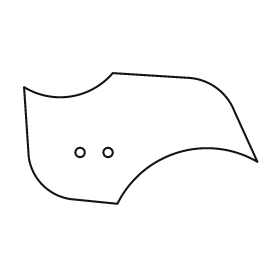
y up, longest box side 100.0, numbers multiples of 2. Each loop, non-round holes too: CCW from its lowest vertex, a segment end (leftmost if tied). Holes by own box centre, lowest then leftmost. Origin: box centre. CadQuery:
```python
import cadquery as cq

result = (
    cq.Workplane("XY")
    .moveTo(-10.0, -28.0)
    .threePointArc((16.0, -6.0), (50.0, -10.0))
    .lineTo(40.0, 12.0)
    .threePointArc((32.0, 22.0), (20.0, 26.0))
    .lineTo(-12.0, 28.0)
    .threePointArc((-30.0, 18.0), (-50.0, 22.0))
    .lineTo(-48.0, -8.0)
    .threePointArc((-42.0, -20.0), (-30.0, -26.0))
    .close()
    .moveTo(-26.0, -6.0)
    .circle(2.0)
    .moveTo(-14.0, -6.0)
    .circle(2.0)
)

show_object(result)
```